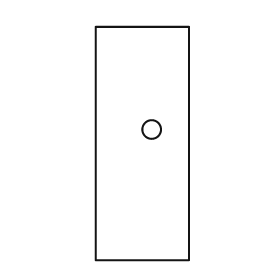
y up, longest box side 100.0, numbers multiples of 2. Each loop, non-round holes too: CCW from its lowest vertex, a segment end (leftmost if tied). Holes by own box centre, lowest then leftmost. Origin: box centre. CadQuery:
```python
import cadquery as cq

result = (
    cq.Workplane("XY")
    .moveTo(-20.0, -50.0)
    .lineTo(20.0, -50.0)
    .lineTo(20.0, 50.0)
    .lineTo(-20.0, 50.0)
    .close()
    .moveTo(4.0, 6.0)
    .circle(4.0)
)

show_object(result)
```